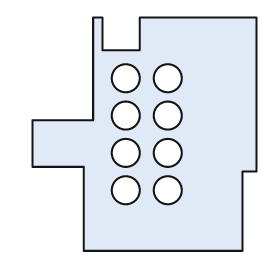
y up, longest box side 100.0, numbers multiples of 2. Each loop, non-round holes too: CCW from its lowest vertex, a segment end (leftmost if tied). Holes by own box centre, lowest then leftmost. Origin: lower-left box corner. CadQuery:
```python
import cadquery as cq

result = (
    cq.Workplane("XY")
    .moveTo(22.0, 0.0)
    .lineTo(90.0, 0.0)
    .lineTo(90.0, 34.0)
    .lineTo(96.0, 34.0)
    .lineTo(96.0, 100.0)
    .lineTo(46.0, 100.0)
    .lineTo(46.0, 86.0)
    .lineTo(30.0, 86.0)
    .lineTo(30.0, 100.0)
    .lineTo(26.0, 100.0)
    .lineTo(26.0, 56.0)
    .lineTo(0.0, 56.0)
    .lineTo(0.0, 36.0)
    .lineTo(22.0, 36.0)
    .close()
    .moveTo(40.0, 26.0)
    .circle(6.0)
    .moveTo(58.0, 26.0)
    .circle(6.0)
    .moveTo(40.0, 42.0)
    .circle(6.0)
    .moveTo(58.0, 42.0)
    .circle(6.0)
    .moveTo(40.0, 58.0)
    .circle(6.0)
    .moveTo(58.0, 58.0)
    .circle(6.0)
    .moveTo(40.0, 74.0)
    .circle(6.0)
    .moveTo(58.0, 74.0)
    .circle(6.0)
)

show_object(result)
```